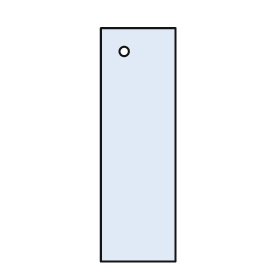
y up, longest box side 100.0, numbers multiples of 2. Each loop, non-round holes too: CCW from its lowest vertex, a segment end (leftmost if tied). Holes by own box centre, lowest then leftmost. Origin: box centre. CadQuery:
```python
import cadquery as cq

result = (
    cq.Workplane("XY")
    .moveTo(-16.0, -50.0)
    .lineTo(16.0, -50.0)
    .lineTo(16.0, 50.0)
    .lineTo(-16.0, 50.0)
    .close()
    .moveTo(-6.0, 40.0)
    .circle(2.0)
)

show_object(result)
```